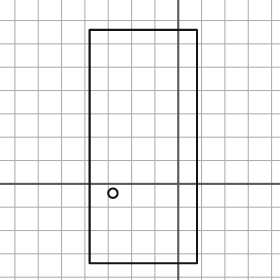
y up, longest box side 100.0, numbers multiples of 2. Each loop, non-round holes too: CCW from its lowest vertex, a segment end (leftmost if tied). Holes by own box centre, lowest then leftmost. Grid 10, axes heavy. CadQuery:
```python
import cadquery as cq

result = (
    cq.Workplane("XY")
    .moveTo(-38.0, -34.0)
    .lineTo(8.0, -34.0)
    .lineTo(8.0, 66.0)
    .lineTo(-38.0, 66.0)
    .close()
    .moveTo(-28.0, -4.0)
    .circle(2.0)
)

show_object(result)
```